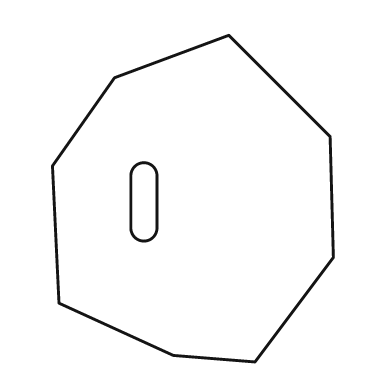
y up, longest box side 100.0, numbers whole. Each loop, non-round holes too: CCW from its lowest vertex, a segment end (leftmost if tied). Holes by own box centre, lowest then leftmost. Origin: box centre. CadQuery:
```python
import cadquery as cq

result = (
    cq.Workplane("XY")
    .moveTo(19.0, -50.0)
    .lineTo(43.0, -18.0)
    .lineTo(42.0, 19.0)
    .lineTo(11.0, 50.0)
    .lineTo(-24.0, 37.0)
    .lineTo(-43.0, 10.0)
    .lineTo(-41.0, -32.0)
    .lineTo(-6.0, -48.0)
    .close()
    .moveTo(-19.0, -9.0)
    .threePointArc((-15.0, -13.0), (-11.0, -9.0))
    .lineTo(-11.0, 7.0)
    .threePointArc((-15.0, 11.0), (-19.0, 7.0))
    .close()
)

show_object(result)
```